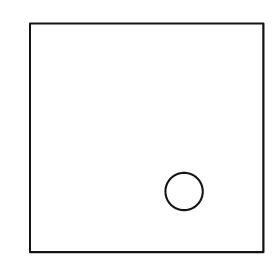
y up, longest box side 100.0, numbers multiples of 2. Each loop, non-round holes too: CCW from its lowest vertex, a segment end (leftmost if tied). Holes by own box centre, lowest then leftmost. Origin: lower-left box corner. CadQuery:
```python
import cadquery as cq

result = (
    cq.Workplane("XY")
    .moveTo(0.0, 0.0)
    .lineTo(100.0, 0.0)
    .lineTo(100.0, 98.0)
    .lineTo(0.0, 98.0)
    .close()
    .moveTo(66.0, 26.0)
    .circle(8.0)
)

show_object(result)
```